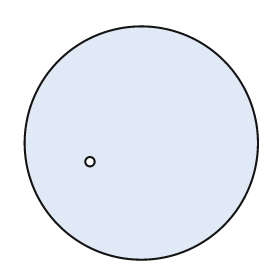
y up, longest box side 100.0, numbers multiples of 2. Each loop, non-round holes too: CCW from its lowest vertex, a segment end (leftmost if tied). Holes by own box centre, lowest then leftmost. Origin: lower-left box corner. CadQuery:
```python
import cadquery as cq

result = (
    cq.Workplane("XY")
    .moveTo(50.0, 50.0)
    .circle(50.0)
    .moveTo(28.0, 42.0)
    .circle(2.0)
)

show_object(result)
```